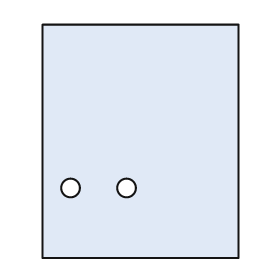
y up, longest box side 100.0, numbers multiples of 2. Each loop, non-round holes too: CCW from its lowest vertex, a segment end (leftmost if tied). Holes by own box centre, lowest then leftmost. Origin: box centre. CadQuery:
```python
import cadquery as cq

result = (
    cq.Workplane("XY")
    .moveTo(-42.0, -50.0)
    .lineTo(42.0, -50.0)
    .lineTo(42.0, 50.0)
    .lineTo(-42.0, 50.0)
    .close()
    .moveTo(-30.0, -20.0)
    .circle(4.0)
    .moveTo(-6.0, -20.0)
    .circle(4.0)
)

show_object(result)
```